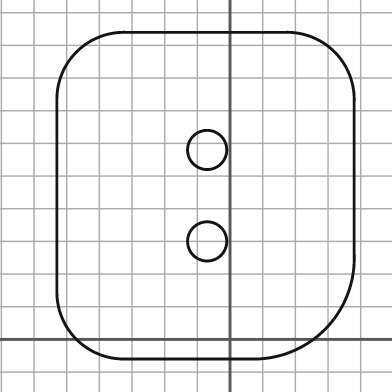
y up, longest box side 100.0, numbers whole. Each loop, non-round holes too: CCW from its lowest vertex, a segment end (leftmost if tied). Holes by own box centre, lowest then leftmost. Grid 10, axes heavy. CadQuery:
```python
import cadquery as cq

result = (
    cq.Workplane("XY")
    .moveTo(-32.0, -6.0)
    .lineTo(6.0, -6.0)
    .threePointArc((29.0, 3.0), (38.0, 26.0))
    .lineTo(38.0, 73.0)
    .threePointArc((32.0, 88.0), (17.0, 94.0))
    .lineTo(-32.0, 94.0)
    .threePointArc((-47.0, 88.0), (-53.0, 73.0))
    .lineTo(-53.0, 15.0)
    .threePointArc((-47.0, 0.0), (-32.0, -6.0))
    .close()
    .moveTo(-7.0, 30.0)
    .circle(6.0)
    .moveTo(-7.0, 58.0)
    .circle(6.0)
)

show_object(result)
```